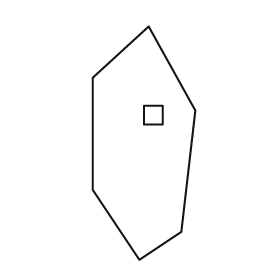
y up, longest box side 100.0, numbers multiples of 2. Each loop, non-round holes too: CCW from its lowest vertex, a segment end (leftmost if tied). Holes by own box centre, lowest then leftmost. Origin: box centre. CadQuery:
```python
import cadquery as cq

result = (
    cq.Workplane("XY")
    .moveTo(-2.0, -50.0)
    .lineTo(16.0, -38.0)
    .lineTo(22.0, 14.0)
    .lineTo(2.0, 50.0)
    .lineTo(-22.0, 28.0)
    .lineTo(-22.0, -20.0)
    .close()
    .moveTo(0.0, 8.0)
    .lineTo(8.0, 8.0)
    .lineTo(8.0, 16.0)
    .lineTo(0.0, 16.0)
    .close()
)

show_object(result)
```